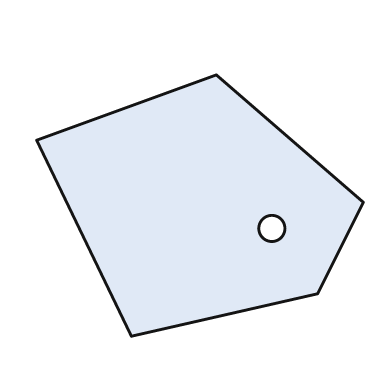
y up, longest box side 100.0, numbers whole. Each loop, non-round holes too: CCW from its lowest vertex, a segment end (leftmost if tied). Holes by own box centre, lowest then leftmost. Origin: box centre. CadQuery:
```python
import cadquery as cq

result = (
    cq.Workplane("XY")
    .moveTo(-21.0, -40.0)
    .lineTo(36.0, -27.0)
    .lineTo(50.0, 1.0)
    .lineTo(5.0, 40.0)
    .lineTo(-50.0, 20.0)
    .close()
    .moveTo(22.0, -7.0)
    .circle(4.0)
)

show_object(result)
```